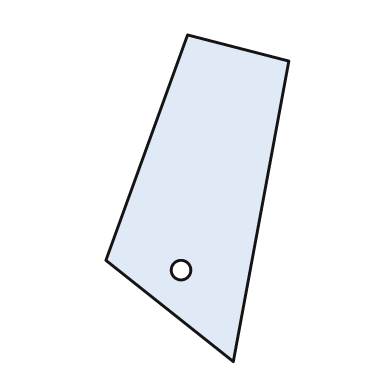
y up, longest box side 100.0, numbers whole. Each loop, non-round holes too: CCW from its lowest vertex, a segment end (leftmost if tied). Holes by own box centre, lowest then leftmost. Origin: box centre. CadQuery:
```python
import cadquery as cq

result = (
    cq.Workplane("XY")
    .moveTo(11.0, -50.0)
    .lineTo(28.0, 42.0)
    .lineTo(-3.0, 50.0)
    .lineTo(-28.0, -19.0)
    .close()
    .moveTo(-5.0, -22.0)
    .circle(3.0)
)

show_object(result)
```